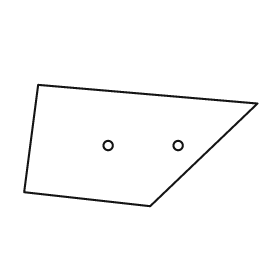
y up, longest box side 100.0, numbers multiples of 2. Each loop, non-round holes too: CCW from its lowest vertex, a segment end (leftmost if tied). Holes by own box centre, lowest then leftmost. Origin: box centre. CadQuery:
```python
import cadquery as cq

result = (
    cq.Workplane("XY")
    .moveTo(4.0, -26.0)
    .lineTo(50.0, 18.0)
    .lineTo(-44.0, 26.0)
    .lineTo(-50.0, -20.0)
    .close()
    .moveTo(-14.0, 0.0)
    .circle(2.0)
    .moveTo(16.0, 0.0)
    .circle(2.0)
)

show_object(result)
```